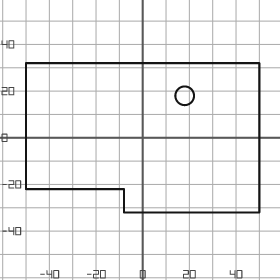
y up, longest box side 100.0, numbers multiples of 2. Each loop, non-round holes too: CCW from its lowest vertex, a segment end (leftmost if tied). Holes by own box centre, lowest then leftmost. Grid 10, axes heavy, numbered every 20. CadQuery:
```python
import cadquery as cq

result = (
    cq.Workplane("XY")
    .moveTo(-8.0, -32.0)
    .lineTo(50.0, -32.0)
    .lineTo(50.0, 32.0)
    .lineTo(-50.0, 32.0)
    .lineTo(-50.0, -22.0)
    .lineTo(-8.0, -22.0)
    .close()
    .moveTo(18.0, 18.0)
    .circle(4.0)
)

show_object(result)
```